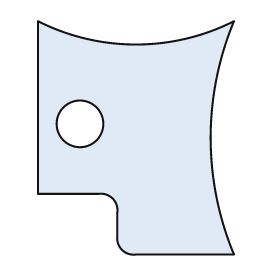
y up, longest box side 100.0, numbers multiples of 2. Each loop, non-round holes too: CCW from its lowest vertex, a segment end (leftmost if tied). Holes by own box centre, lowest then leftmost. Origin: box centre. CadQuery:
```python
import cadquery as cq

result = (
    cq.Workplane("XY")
    .moveTo(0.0, -50.0)
    .lineTo(42.0, -50.0)
    .threePointArc((32.0, 0.0), (42.0, 50.0))
    .threePointArc((0.0, 40.0), (-42.0, 50.0))
    .lineTo(-42.0, -24.0)
    .lineTo(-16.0, -24.0)
    .threePointArc((-10.0, -26.0), (-8.0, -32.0))
    .lineTo(-8.0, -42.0)
    .threePointArc((-6.0, -48.0), (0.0, -50.0))
    .close()
    .moveTo(-24.0, 6.0)
    .circle(10.0)
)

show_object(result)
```